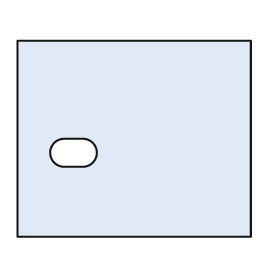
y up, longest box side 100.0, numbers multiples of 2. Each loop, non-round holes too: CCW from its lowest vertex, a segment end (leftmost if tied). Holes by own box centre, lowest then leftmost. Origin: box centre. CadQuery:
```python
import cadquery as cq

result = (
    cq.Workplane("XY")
    .moveTo(-50.0, -42.0)
    .lineTo(50.0, -42.0)
    .lineTo(50.0, 42.0)
    .lineTo(-50.0, 42.0)
    .close()
    .moveTo(-30.0, -12.0)
    .lineTo(-22.0, -12.0)
    .threePointArc((-16.0, -6.0), (-22.0, 0.0))
    .lineTo(-30.0, 0.0)
    .threePointArc((-36.0, -6.0), (-30.0, -12.0))
    .close()
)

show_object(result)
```